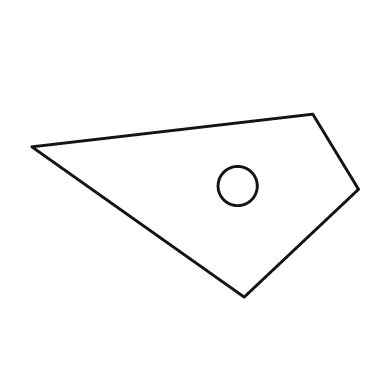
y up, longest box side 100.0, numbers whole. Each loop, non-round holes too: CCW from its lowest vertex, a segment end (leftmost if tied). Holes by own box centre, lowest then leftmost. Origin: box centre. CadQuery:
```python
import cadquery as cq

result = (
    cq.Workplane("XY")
    .moveTo(15.0, -28.0)
    .lineTo(50.0, 5.0)
    .lineTo(36.0, 28.0)
    .lineTo(-50.0, 18.0)
    .close()
    .moveTo(13.0, 6.0)
    .circle(6.0)
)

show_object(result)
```